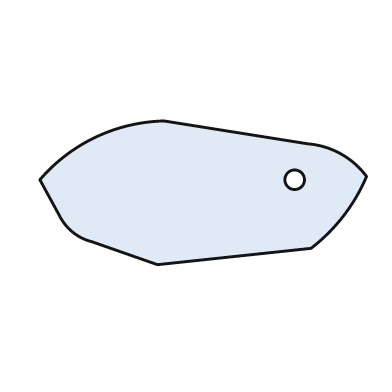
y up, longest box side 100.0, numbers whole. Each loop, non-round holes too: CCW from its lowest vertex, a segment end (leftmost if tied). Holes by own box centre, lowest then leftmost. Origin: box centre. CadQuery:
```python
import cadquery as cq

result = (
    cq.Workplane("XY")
    .moveTo(-14.0, -22.0)
    .lineTo(33.0, -17.0)
    .threePointArc((43.0, -7.0), (50.0, 5.0))
    .threePointArc((42.0, 12.0), (32.0, 15.0))
    .lineTo(-12.0, 22.0)
    .threePointArc((-33.0, 17.0), (-50.0, 4.0))
    .lineTo(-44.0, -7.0)
    .threePointArc((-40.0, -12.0), (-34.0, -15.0))
    .close()
    .moveTo(28.0, 4.0)
    .circle(3.0)
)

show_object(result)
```